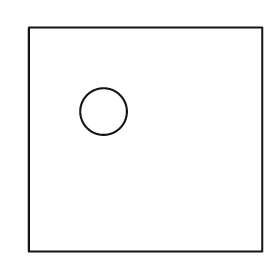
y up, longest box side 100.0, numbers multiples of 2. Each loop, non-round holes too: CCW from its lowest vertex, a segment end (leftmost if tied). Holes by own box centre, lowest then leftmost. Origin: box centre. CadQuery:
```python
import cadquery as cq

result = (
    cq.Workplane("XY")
    .moveTo(-50.0, -48.0)
    .lineTo(50.0, -48.0)
    .lineTo(50.0, 48.0)
    .lineTo(-50.0, 48.0)
    .close()
    .moveTo(-18.0, 12.0)
    .circle(10.0)
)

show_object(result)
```